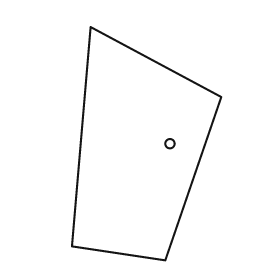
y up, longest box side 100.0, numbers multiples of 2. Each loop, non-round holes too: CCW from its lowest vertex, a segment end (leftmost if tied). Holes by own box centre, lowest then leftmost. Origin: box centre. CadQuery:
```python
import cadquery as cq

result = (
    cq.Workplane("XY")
    .moveTo(8.0, -50.0)
    .lineTo(32.0, 20.0)
    .lineTo(-24.0, 50.0)
    .lineTo(-32.0, -44.0)
    .close()
    .moveTo(10.0, 0.0)
    .circle(2.0)
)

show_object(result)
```